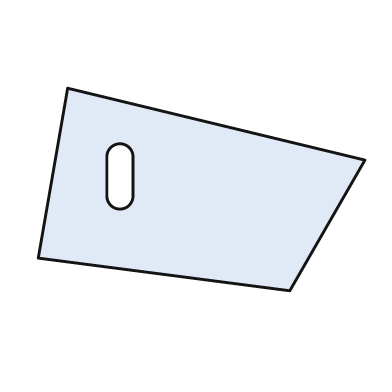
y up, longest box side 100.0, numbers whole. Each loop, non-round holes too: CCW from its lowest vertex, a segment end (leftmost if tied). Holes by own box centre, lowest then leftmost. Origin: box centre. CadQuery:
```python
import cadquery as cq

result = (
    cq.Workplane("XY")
    .moveTo(27.0, -31.0)
    .lineTo(50.0, 9.0)
    .lineTo(-41.0, 31.0)
    .lineTo(-50.0, -21.0)
    .close()
    .moveTo(-29.0, -2.0)
    .threePointArc((-25.0, -6.0), (-21.0, -2.0))
    .lineTo(-21.0, 10.0)
    .threePointArc((-25.0, 14.0), (-29.0, 10.0))
    .close()
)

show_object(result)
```